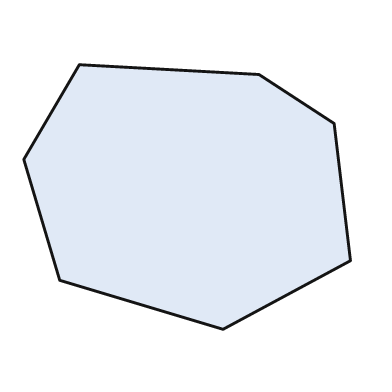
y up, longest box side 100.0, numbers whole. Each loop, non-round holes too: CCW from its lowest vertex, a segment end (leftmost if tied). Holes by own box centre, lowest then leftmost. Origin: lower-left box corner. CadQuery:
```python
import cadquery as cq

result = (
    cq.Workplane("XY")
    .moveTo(61.0, 0.0)
    .lineTo(100.0, 21.0)
    .lineTo(95.0, 63.0)
    .lineTo(72.0, 78.0)
    .lineTo(17.0, 81.0)
    .lineTo(0.0, 52.0)
    .lineTo(11.0, 15.0)
    .close()
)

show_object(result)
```